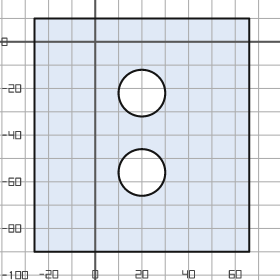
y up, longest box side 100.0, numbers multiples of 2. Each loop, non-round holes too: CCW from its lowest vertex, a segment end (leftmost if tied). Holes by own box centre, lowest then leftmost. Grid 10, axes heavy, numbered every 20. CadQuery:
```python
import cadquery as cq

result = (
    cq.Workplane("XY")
    .moveTo(-26.0, -90.0)
    .lineTo(66.0, -90.0)
    .lineTo(66.0, 10.0)
    .lineTo(-26.0, 10.0)
    .close()
    .moveTo(20.0, -56.0)
    .circle(10.0)
    .moveTo(20.0, -22.0)
    .circle(10.0)
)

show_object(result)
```